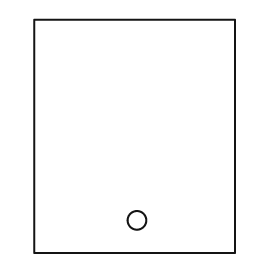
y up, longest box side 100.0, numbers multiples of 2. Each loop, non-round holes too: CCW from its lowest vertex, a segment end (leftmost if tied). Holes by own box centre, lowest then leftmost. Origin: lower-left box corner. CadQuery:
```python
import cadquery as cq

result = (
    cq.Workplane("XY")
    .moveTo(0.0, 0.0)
    .lineTo(86.0, 0.0)
    .lineTo(86.0, 100.0)
    .lineTo(0.0, 100.0)
    .close()
    .moveTo(44.0, 14.0)
    .circle(4.0)
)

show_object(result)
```